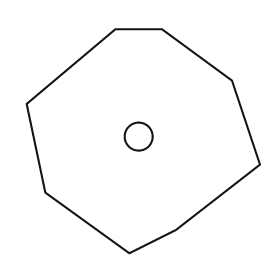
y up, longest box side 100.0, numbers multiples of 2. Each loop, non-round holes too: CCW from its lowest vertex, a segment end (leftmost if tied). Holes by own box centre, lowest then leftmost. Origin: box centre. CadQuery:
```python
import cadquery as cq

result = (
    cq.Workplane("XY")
    .moveTo(-6.0, -48.0)
    .lineTo(14.0, -38.0)
    .lineTo(50.0, -10.0)
    .lineTo(38.0, 26.0)
    .lineTo(8.0, 48.0)
    .lineTo(-12.0, 48.0)
    .lineTo(-50.0, 16.0)
    .lineTo(-42.0, -22.0)
    .close()
    .moveTo(-2.0, 2.0)
    .circle(6.0)
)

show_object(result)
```